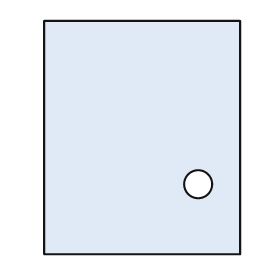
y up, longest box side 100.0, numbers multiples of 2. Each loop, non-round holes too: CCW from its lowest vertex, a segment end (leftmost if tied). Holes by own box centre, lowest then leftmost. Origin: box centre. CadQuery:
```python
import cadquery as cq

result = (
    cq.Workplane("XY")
    .moveTo(-42.0, -50.0)
    .lineTo(42.0, -50.0)
    .lineTo(42.0, 50.0)
    .lineTo(-42.0, 50.0)
    .close()
    .moveTo(24.0, -20.0)
    .circle(6.0)
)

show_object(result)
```